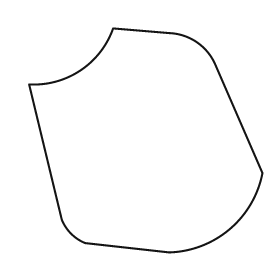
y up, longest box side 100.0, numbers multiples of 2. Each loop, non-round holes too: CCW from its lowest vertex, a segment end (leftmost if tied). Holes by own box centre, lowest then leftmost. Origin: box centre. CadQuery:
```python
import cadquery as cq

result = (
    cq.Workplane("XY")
    .moveTo(10.0, -48.0)
    .threePointArc((36.0, -38.0), (50.0, -14.0))
    .lineTo(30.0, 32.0)
    .threePointArc((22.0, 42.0), (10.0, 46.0))
    .lineTo(-14.0, 48.0)
    .threePointArc((-28.0, 30.0), (-50.0, 24.0))
    .lineTo(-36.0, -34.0)
    .threePointArc((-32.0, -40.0), (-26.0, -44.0))
    .close()
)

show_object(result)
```